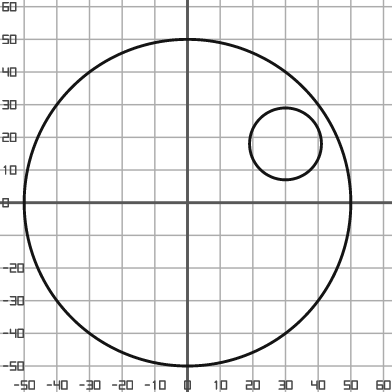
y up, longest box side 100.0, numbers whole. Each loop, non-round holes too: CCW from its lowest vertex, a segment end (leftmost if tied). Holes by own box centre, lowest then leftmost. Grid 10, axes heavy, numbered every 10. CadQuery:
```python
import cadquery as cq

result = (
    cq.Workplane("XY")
    .moveTo(0.0, 0.0)
    .circle(50.0)
    .moveTo(30.0, 18.0)
    .circle(11.0)
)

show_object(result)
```